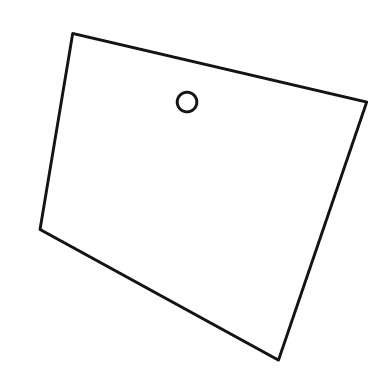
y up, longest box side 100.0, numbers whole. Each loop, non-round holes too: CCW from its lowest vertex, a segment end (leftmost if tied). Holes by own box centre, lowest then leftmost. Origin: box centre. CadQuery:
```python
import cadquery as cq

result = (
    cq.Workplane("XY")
    .moveTo(23.0, -50.0)
    .lineTo(50.0, 29.0)
    .lineTo(-40.0, 50.0)
    .lineTo(-50.0, -10.0)
    .close()
    .moveTo(-5.0, 29.0)
    .circle(3.0)
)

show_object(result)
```